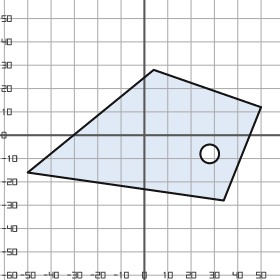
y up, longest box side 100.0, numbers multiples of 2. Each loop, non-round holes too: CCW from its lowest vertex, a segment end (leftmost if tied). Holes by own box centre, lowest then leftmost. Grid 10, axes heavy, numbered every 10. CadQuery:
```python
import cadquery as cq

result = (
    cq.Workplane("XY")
    .moveTo(34.0, -28.0)
    .lineTo(50.0, 12.0)
    .lineTo(4.0, 28.0)
    .lineTo(-50.0, -16.0)
    .close()
    .moveTo(28.0, -8.0)
    .circle(4.0)
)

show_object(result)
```